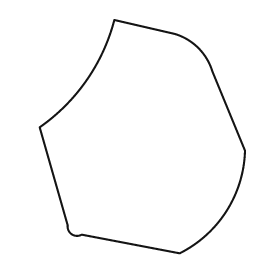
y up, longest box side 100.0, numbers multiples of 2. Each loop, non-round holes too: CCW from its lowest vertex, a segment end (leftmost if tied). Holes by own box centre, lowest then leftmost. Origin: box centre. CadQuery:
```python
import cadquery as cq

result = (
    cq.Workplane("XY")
    .moveTo(16.0, -50.0)
    .threePointArc((36.0, -32.0), (44.0, -6.0))
    .lineTo(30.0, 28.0)
    .threePointArc((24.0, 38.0), (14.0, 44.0))
    .lineTo(-12.0, 50.0)
    .threePointArc((-24.0, 24.0), (-44.0, 4.0))
    .lineTo(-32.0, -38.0)
    .threePointArc((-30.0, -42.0), (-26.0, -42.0))
    .close()
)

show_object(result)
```